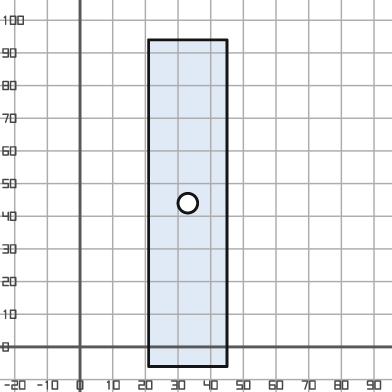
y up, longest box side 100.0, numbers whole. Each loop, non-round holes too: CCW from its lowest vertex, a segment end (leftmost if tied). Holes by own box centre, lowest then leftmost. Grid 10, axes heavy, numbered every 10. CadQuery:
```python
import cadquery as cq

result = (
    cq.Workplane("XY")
    .moveTo(21.0, -6.0)
    .lineTo(45.0, -6.0)
    .lineTo(45.0, 94.0)
    .lineTo(21.0, 94.0)
    .close()
    .moveTo(33.0, 44.0)
    .circle(3.0)
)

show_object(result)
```